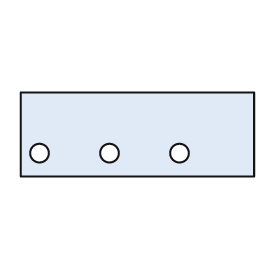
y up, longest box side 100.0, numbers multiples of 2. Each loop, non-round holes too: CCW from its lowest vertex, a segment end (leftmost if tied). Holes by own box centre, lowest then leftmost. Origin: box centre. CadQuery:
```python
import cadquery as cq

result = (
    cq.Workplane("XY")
    .moveTo(-50.0, -18.0)
    .lineTo(50.0, -18.0)
    .lineTo(50.0, 18.0)
    .lineTo(-50.0, 18.0)
    .close()
    .moveTo(-42.0, -8.0)
    .circle(4.0)
    .moveTo(-12.0, -8.0)
    .circle(4.0)
    .moveTo(18.0, -8.0)
    .circle(4.0)
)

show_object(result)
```